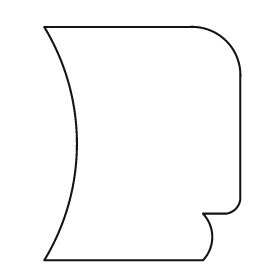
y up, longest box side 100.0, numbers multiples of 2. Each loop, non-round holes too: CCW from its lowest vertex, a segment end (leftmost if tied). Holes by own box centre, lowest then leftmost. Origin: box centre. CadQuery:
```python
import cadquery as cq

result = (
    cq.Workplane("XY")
    .moveTo(-42.0, -50.0)
    .lineTo(26.0, -50.0)
    .threePointArc((30.0, -40.0), (26.0, -30.0))
    .lineTo(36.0, -30.0)
    .threePointArc((40.0, -28.0), (42.0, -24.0))
    .lineTo(42.0, 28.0)
    .threePointArc((36.0, 44.0), (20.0, 50.0))
    .lineTo(-42.0, 50.0)
    .threePointArc((-28.0, 0.0), (-42.0, -50.0))
    .close()
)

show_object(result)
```